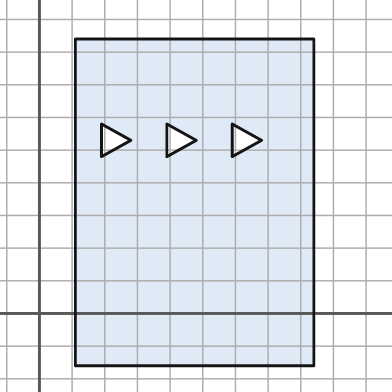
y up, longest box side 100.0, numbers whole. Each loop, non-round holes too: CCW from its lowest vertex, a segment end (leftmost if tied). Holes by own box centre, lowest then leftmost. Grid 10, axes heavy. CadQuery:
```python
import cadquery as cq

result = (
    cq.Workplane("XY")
    .moveTo(11.0, -16.0)
    .lineTo(84.0, -16.0)
    .lineTo(84.0, 84.0)
    .lineTo(11.0, 84.0)
    .close()
    .moveTo(19.0, 48.0)
    .lineTo(28.0, 53.0)
    .lineTo(19.0, 58.0)
    .close()
    .moveTo(39.0, 48.0)
    .lineTo(48.0, 53.0)
    .lineTo(39.0, 58.0)
    .close()
    .moveTo(59.0, 48.0)
    .lineTo(68.0, 53.0)
    .lineTo(59.0, 58.0)
    .close()
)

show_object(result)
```